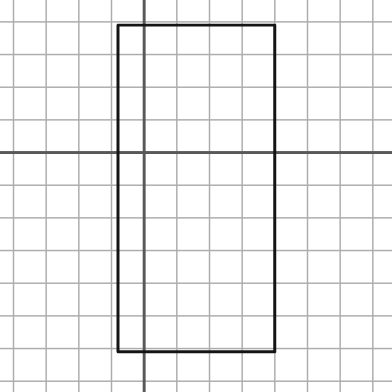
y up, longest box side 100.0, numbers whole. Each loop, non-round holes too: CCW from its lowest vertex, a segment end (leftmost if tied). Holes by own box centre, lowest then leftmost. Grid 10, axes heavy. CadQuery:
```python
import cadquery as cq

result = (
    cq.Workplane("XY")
    .moveTo(-8.0, -61.0)
    .lineTo(40.0, -61.0)
    .lineTo(40.0, 39.0)
    .lineTo(-8.0, 39.0)
    .close()
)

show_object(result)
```